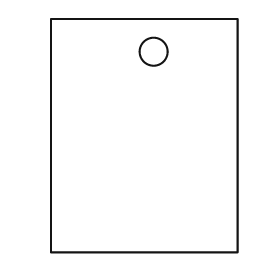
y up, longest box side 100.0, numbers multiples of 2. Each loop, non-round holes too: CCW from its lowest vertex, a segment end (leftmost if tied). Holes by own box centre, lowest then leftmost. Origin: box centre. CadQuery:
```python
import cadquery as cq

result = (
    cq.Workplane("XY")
    .moveTo(-40.0, -50.0)
    .lineTo(40.0, -50.0)
    .lineTo(40.0, 50.0)
    .lineTo(-40.0, 50.0)
    .close()
    .moveTo(4.0, 36.0)
    .circle(6.0)
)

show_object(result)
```